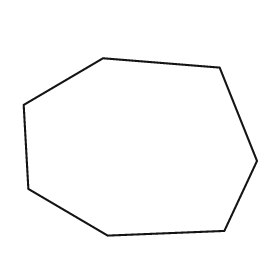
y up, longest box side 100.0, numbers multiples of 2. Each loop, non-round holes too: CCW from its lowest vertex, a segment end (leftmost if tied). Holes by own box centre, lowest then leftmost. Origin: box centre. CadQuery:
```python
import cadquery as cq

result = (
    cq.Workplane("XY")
    .moveTo(-14.0, -38.0)
    .lineTo(36.0, -36.0)
    .lineTo(50.0, -6.0)
    .lineTo(34.0, 34.0)
    .lineTo(-16.0, 38.0)
    .lineTo(-50.0, 18.0)
    .lineTo(-48.0, -18.0)
    .close()
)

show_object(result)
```